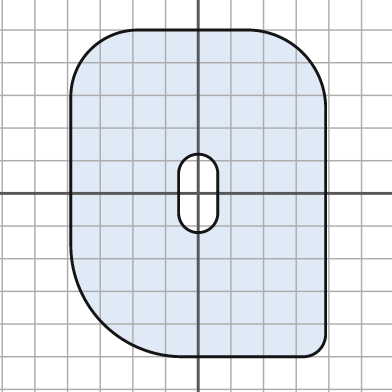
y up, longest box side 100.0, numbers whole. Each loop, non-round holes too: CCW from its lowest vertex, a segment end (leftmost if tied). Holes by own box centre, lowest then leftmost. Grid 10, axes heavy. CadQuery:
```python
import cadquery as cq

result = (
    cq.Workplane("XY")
    .moveTo(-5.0, -50.0)
    .lineTo(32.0, -50.0)
    .threePointArc((37.0, -48.0), (39.0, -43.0))
    .lineTo(39.0, 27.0)
    .threePointArc((32.0, 43.0), (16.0, 50.0))
    .lineTo(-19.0, 50.0)
    .threePointArc((-33.0, 44.0), (-39.0, 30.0))
    .lineTo(-39.0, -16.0)
    .threePointArc((-29.0, -40.0), (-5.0, -50.0))
    .close()
    .moveTo(-6.0, -6.0)
    .threePointArc((0.0, -12.0), (6.0, -6.0))
    .lineTo(6.0, 6.0)
    .threePointArc((0.0, 12.0), (-6.0, 6.0))
    .close()
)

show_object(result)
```